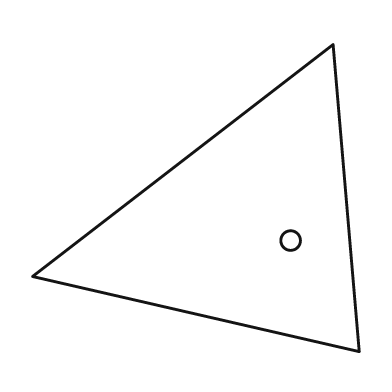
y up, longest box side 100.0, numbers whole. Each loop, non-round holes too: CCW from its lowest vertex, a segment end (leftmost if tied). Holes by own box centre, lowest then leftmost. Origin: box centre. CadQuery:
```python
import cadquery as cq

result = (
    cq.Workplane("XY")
    .moveTo(50.0, -47.0)
    .lineTo(42.0, 47.0)
    .lineTo(-50.0, -24.0)
    .close()
    .moveTo(29.0, -13.0)
    .circle(3.0)
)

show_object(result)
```